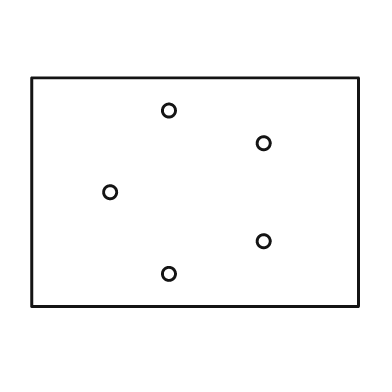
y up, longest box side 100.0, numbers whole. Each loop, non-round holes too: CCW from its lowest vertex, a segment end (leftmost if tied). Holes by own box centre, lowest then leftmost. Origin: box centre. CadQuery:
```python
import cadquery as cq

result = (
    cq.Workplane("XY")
    .moveTo(-50.0, -35.0)
    .lineTo(50.0, -35.0)
    .lineTo(50.0, 35.0)
    .lineTo(-50.0, 35.0)
    .close()
    .moveTo(-8.0, -25.0)
    .circle(2.0)
    .moveTo(21.0, -15.0)
    .circle(2.0)
    .moveTo(-26.0, 0.0)
    .circle(2.0)
    .moveTo(21.0, 15.0)
    .circle(2.0)
    .moveTo(-8.0, 25.0)
    .circle(2.0)
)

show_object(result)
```